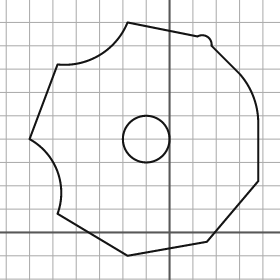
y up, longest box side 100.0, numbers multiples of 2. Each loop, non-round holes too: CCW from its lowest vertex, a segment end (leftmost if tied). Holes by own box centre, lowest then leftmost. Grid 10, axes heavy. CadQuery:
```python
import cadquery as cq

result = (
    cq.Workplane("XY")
    .moveTo(-18.0, -10.0)
    .lineTo(16.0, -4.0)
    .lineTo(38.0, 22.0)
    .lineTo(38.0, 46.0)
    .threePointArc((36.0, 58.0), (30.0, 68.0))
    .lineTo(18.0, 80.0)
    .threePointArc((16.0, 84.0), (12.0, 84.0))
    .lineTo(-18.0, 90.0)
    .threePointArc((-30.0, 76.0), (-48.0, 72.0))
    .lineTo(-60.0, 40.0)
    .threePointArc((-48.0, 26.0), (-48.0, 8.0))
    .close()
    .moveTo(-10.0, 40.0)
    .circle(10.0)
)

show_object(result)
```